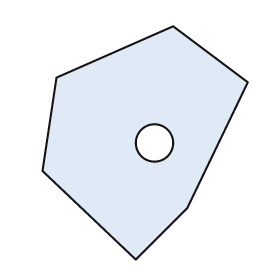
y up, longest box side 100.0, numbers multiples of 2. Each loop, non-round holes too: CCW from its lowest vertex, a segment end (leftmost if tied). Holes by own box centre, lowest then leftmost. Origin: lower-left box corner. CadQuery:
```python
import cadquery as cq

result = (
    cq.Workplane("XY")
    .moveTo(40.0, 0.0)
    .lineTo(62.0, 22.0)
    .lineTo(88.0, 76.0)
    .lineTo(56.0, 100.0)
    .lineTo(6.0, 78.0)
    .lineTo(0.0, 38.0)
    .close()
    .moveTo(48.0, 50.0)
    .circle(8.0)
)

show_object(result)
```